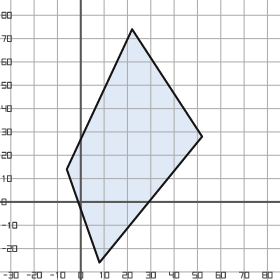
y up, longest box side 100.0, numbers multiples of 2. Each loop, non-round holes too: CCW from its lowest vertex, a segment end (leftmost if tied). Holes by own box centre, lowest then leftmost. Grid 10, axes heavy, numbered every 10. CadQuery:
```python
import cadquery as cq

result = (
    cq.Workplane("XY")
    .moveTo(8.0, -26.0)
    .lineTo(52.0, 28.0)
    .lineTo(22.0, 74.0)
    .lineTo(-6.0, 14.0)
    .close()
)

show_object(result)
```